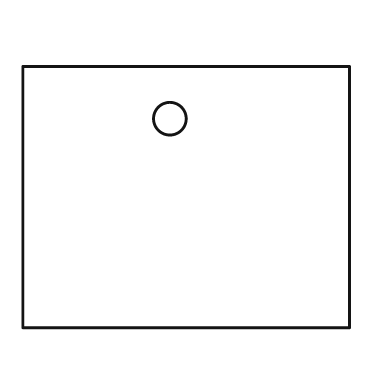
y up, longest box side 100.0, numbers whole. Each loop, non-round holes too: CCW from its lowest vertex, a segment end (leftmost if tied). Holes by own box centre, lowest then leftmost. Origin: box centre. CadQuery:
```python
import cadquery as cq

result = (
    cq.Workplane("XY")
    .moveTo(-50.0, -40.0)
    .lineTo(50.0, -40.0)
    .lineTo(50.0, 40.0)
    .lineTo(-50.0, 40.0)
    .close()
    .moveTo(-5.0, 24.0)
    .circle(5.0)
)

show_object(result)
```